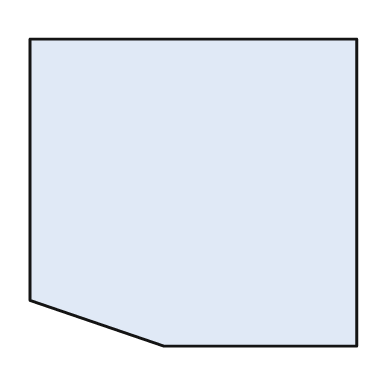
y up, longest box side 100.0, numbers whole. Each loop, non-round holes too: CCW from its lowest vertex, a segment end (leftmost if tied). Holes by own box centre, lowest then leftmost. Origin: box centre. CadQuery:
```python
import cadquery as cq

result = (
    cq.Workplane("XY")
    .moveTo(-9.0, -47.0)
    .lineTo(50.0, -47.0)
    .lineTo(50.0, 47.0)
    .lineTo(-50.0, 47.0)
    .lineTo(-50.0, -33.0)
    .close()
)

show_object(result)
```